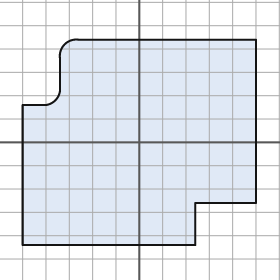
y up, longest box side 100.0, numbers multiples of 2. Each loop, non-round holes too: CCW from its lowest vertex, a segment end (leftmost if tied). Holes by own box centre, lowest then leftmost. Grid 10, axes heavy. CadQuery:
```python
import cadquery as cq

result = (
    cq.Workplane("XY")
    .moveTo(-50.0, -44.0)
    .lineTo(24.0, -44.0)
    .lineTo(24.0, -26.0)
    .lineTo(50.0, -26.0)
    .lineTo(50.0, 44.0)
    .lineTo(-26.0, 44.0)
    .threePointArc((-32.0, 42.0), (-34.0, 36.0))
    .lineTo(-34.0, 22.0)
    .threePointArc((-36.0, 18.0), (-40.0, 16.0))
    .lineTo(-50.0, 16.0)
    .close()
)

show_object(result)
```